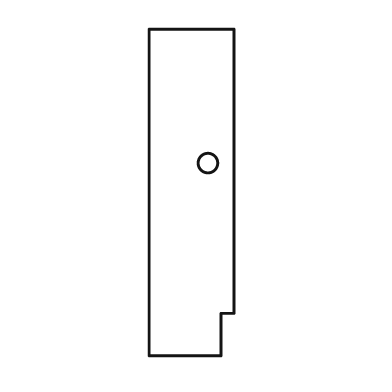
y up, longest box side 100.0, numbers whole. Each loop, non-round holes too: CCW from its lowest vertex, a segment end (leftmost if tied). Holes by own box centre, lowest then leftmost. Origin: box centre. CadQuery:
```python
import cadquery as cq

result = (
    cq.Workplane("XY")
    .moveTo(-13.0, -50.0)
    .lineTo(9.0, -50.0)
    .lineTo(9.0, -37.0)
    .lineTo(13.0, -37.0)
    .lineTo(13.0, 50.0)
    .lineTo(-13.0, 50.0)
    .close()
    .moveTo(5.0, 9.0)
    .circle(3.0)
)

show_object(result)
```